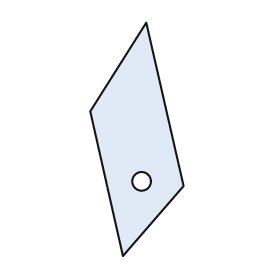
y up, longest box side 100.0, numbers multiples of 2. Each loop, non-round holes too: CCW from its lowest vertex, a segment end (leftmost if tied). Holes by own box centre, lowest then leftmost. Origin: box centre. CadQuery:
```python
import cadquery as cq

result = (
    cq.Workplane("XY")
    .moveTo(-6.0, -50.0)
    .lineTo(20.0, -20.0)
    .lineTo(4.0, 50.0)
    .lineTo(-20.0, 12.0)
    .close()
    .moveTo(2.0, -18.0)
    .circle(4.0)
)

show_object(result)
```